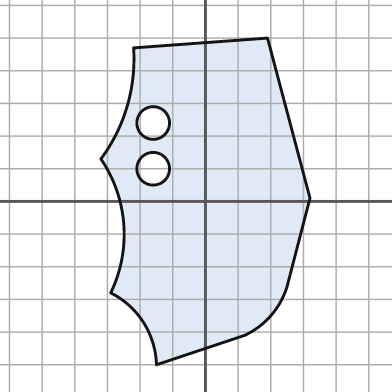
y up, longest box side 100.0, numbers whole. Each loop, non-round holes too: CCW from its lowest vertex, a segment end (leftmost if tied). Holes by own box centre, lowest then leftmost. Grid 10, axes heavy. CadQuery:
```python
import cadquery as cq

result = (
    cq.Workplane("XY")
    .moveTo(-15.0, -50.0)
    .lineTo(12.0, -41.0)
    .threePointArc((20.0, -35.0), (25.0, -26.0))
    .lineTo(32.0, 1.0)
    .lineTo(19.0, 50.0)
    .lineTo(-22.0, 47.0)
    .threePointArc((-24.0, 29.0), (-32.0, 13.0))
    .threePointArc((-25.0, -7.0), (-29.0, -28.0))
    .threePointArc((-19.0, -37.0), (-15.0, -50.0))
    .close()
    .moveTo(-16.0, 10.0)
    .circle(5.0)
    .moveTo(-16.0, 24.0)
    .circle(5.0)
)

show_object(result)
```